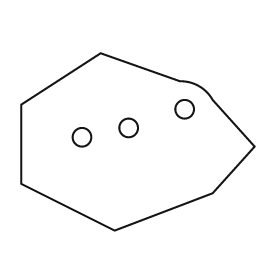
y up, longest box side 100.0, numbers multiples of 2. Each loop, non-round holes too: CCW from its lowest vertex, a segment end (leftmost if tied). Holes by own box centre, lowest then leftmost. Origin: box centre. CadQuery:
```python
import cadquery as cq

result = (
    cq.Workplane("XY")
    .moveTo(-10.0, -38.0)
    .lineTo(32.0, -22.0)
    .lineTo(50.0, -2.0)
    .lineTo(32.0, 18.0)
    .threePointArc((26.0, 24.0), (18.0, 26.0))
    .lineTo(-16.0, 38.0)
    .lineTo(-50.0, 16.0)
    .lineTo(-50.0, -18.0)
    .close()
    .moveTo(-24.0, 2.0)
    .circle(4.0)
    .moveTo(-4.0, 6.0)
    .circle(4.0)
    .moveTo(20.0, 14.0)
    .circle(4.0)
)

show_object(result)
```